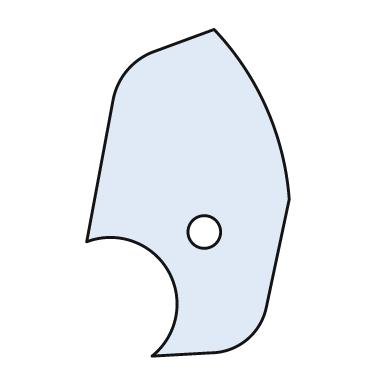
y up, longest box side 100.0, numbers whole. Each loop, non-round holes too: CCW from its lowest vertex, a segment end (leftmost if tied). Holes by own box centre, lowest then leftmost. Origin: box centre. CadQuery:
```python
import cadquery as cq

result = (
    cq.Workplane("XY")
    .moveTo(-11.0, -50.0)
    .lineTo(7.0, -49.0)
    .threePointArc((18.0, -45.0), (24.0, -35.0))
    .lineTo(31.0, -2.0)
    .threePointArc((24.0, 26.0), (8.0, 50.0))
    .lineTo(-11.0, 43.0)
    .threePointArc((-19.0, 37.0), (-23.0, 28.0))
    .lineTo(-31.0, -15.0)
    .threePointArc((-6.0, -24.0), (-11.0, -50.0))
    .close()
    .moveTo(5.0, -12.0)
    .circle(5.0)
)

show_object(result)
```